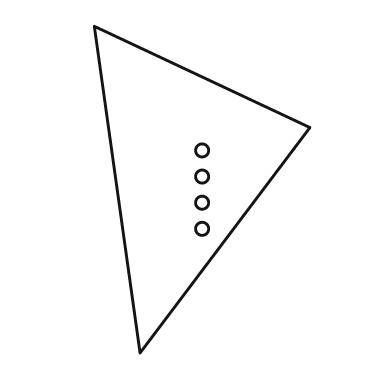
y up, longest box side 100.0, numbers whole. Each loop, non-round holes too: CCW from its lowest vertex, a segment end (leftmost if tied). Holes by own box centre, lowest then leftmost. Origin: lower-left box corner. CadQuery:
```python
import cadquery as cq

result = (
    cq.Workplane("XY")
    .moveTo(14.0, 0.0)
    .lineTo(66.0, 69.0)
    .lineTo(0.0, 100.0)
    .close()
    .moveTo(33.0, 38.0)
    .circle(2.0)
    .moveTo(33.0, 46.0)
    .circle(2.0)
    .moveTo(33.0, 54.0)
    .circle(2.0)
    .moveTo(33.0, 62.0)
    .circle(2.0)
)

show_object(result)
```